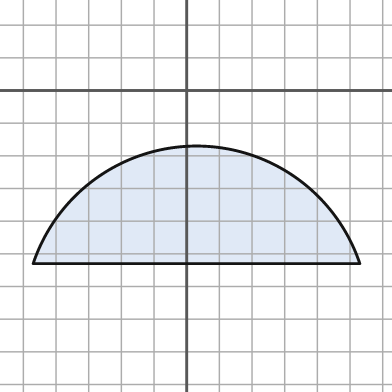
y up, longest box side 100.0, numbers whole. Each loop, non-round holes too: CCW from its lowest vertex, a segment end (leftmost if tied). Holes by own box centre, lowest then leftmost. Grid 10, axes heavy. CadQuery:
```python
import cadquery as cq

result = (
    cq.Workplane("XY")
    .moveTo(-47.0, -53.0)
    .lineTo(53.0, -53.0)
    .threePointArc((3.0, -17.0), (-47.0, -53.0))
    .close()
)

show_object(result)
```